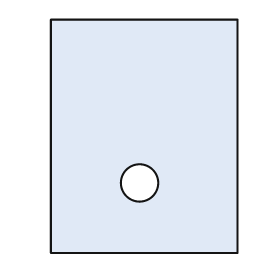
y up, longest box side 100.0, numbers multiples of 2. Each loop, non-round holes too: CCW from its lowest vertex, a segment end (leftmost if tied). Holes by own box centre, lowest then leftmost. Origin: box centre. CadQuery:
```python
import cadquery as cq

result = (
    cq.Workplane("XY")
    .moveTo(-40.0, -50.0)
    .lineTo(40.0, -50.0)
    .lineTo(40.0, 50.0)
    .lineTo(-40.0, 50.0)
    .close()
    .moveTo(-2.0, -20.0)
    .circle(8.0)
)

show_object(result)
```